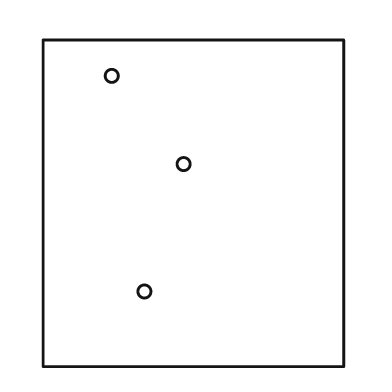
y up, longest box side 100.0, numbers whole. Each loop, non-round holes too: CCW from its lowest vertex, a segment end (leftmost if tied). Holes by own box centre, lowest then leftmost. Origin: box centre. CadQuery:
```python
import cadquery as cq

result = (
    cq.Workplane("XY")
    .moveTo(-46.0, -50.0)
    .lineTo(46.0, -50.0)
    .lineTo(46.0, 50.0)
    .lineTo(-46.0, 50.0)
    .close()
    .moveTo(-15.0, -27.0)
    .circle(2.0)
    .moveTo(-3.0, 12.0)
    .circle(2.0)
    .moveTo(-25.0, 39.0)
    .circle(2.0)
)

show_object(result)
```